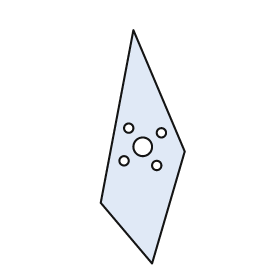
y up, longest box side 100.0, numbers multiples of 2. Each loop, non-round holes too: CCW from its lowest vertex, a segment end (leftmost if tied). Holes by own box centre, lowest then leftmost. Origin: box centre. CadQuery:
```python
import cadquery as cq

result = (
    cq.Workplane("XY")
    .moveTo(4.0, -50.0)
    .lineTo(18.0, -2.0)
    .lineTo(-4.0, 50.0)
    .lineTo(-18.0, -24.0)
    .close()
    .moveTo(6.0, -8.0)
    .circle(2.0)
    .moveTo(-8.0, -6.0)
    .circle(2.0)
    .moveTo(0.0, 0.0)
    .circle(4.0)
    .moveTo(8.0, 6.0)
    .circle(2.0)
    .moveTo(-6.0, 8.0)
    .circle(2.0)
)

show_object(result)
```